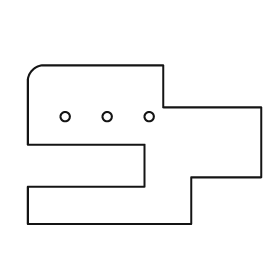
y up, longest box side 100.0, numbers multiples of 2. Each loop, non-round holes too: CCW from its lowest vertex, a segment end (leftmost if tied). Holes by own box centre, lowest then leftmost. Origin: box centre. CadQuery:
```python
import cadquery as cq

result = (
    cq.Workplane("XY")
    .moveTo(-50.0, -34.0)
    .lineTo(20.0, -34.0)
    .lineTo(20.0, -14.0)
    .lineTo(50.0, -14.0)
    .lineTo(50.0, 16.0)
    .lineTo(8.0, 16.0)
    .lineTo(8.0, 34.0)
    .lineTo(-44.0, 34.0)
    .threePointArc((-48.0, 32.0), (-50.0, 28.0))
    .lineTo(-50.0, 0.0)
    .lineTo(0.0, 0.0)
    .lineTo(0.0, -18.0)
    .lineTo(-50.0, -18.0)
    .close()
    .moveTo(-34.0, 12.0)
    .circle(2.0)
    .moveTo(-16.0, 12.0)
    .circle(2.0)
    .moveTo(2.0, 12.0)
    .circle(2.0)
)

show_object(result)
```